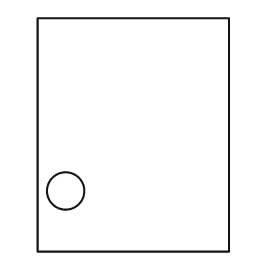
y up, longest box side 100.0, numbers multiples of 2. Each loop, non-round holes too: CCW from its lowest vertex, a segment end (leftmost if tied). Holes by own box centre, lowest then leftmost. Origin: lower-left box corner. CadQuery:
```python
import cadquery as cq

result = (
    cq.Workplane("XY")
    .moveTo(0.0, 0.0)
    .lineTo(82.0, 0.0)
    .lineTo(82.0, 100.0)
    .lineTo(0.0, 100.0)
    .close()
    .moveTo(12.0, 26.0)
    .circle(8.0)
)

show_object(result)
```